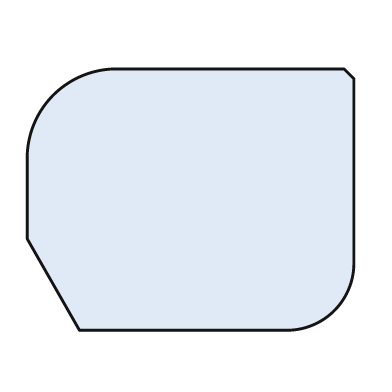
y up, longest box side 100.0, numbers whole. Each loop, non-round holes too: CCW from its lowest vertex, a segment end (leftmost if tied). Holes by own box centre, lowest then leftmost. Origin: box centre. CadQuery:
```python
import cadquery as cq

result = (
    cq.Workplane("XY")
    .moveTo(-34.0, -40.0)
    .lineTo(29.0, -40.0)
    .threePointArc((44.0, -34.0), (50.0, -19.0))
    .lineTo(50.0, 37.0)
    .lineTo(47.0, 40.0)
    .lineTo(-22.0, 40.0)
    .threePointArc((-42.0, 32.0), (-50.0, 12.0))
    .lineTo(-50.0, -12.0)
    .close()
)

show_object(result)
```